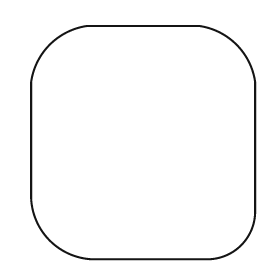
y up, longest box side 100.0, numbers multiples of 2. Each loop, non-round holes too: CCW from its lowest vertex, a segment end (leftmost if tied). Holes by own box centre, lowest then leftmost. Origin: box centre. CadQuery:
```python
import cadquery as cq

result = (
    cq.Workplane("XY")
    .moveTo(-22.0, -50.0)
    .lineTo(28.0, -50.0)
    .threePointArc((42.0, -44.0), (48.0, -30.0))
    .lineTo(48.0, 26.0)
    .threePointArc((40.0, 42.0), (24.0, 50.0))
    .lineTo(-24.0, 50.0)
    .threePointArc((-40.0, 42.0), (-48.0, 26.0))
    .lineTo(-48.0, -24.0)
    .threePointArc((-40.0, -42.0), (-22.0, -50.0))
    .close()
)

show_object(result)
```